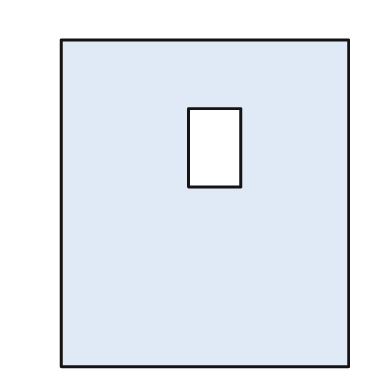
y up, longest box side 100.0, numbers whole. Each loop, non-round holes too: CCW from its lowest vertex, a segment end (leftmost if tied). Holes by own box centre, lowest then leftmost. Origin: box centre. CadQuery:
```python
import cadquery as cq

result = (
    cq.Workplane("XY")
    .moveTo(-44.0, -50.0)
    .lineTo(44.0, -50.0)
    .lineTo(44.0, 50.0)
    .lineTo(-44.0, 50.0)
    .close()
    .moveTo(-5.0, 5.0)
    .lineTo(11.0, 5.0)
    .lineTo(11.0, 29.0)
    .lineTo(-5.0, 29.0)
    .close()
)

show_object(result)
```